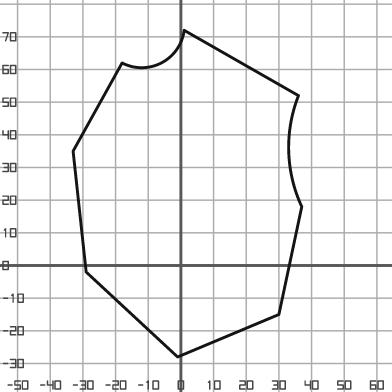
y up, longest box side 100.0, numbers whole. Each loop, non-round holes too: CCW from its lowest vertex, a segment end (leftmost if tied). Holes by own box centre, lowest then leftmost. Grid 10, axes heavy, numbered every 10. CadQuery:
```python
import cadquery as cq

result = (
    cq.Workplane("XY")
    .moveTo(-1.0, -28.0)
    .lineTo(30.0, -15.0)
    .lineTo(37.0, 18.0)
    .threePointArc((33.0, 35.0), (36.0, 52.0))
    .lineTo(1.0, 72.0)
    .threePointArc((-6.0, 62.0), (-18.0, 62.0))
    .lineTo(-33.0, 35.0)
    .lineTo(-29.0, -2.0)
    .close()
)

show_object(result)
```